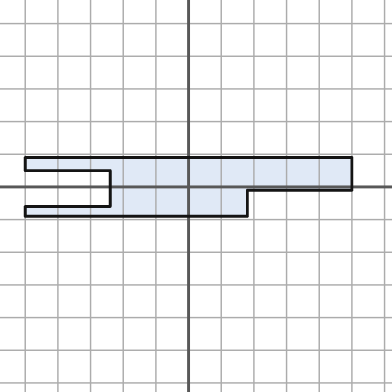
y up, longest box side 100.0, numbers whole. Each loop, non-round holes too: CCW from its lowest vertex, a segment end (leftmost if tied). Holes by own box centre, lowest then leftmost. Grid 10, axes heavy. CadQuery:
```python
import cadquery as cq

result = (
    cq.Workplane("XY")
    .moveTo(-50.0, -9.0)
    .lineTo(18.0, -9.0)
    .lineTo(18.0, -1.0)
    .lineTo(50.0, -1.0)
    .lineTo(50.0, 9.0)
    .lineTo(-50.0, 9.0)
    .lineTo(-50.0, 5.0)
    .lineTo(-24.0, 5.0)
    .lineTo(-24.0, -6.0)
    .lineTo(-50.0, -6.0)
    .close()
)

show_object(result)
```